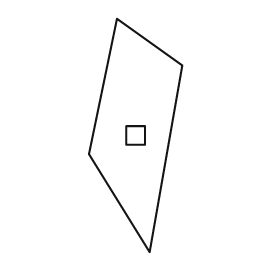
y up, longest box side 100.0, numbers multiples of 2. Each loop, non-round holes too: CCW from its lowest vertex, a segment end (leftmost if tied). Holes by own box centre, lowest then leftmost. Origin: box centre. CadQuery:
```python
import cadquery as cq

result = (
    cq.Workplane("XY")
    .moveTo(6.0, -50.0)
    .lineTo(20.0, 30.0)
    .lineTo(-8.0, 50.0)
    .lineTo(-20.0, -8.0)
    .close()
    .moveTo(-4.0, -4.0)
    .lineTo(4.0, -4.0)
    .lineTo(4.0, 4.0)
    .lineTo(-4.0, 4.0)
    .close()
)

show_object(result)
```